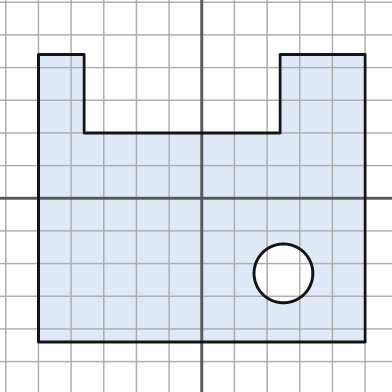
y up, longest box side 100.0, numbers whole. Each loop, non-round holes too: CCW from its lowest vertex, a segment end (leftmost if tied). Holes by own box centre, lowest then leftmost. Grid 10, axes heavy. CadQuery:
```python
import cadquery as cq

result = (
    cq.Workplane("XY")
    .moveTo(-50.0, -44.0)
    .lineTo(50.0, -44.0)
    .lineTo(50.0, 44.0)
    .lineTo(24.0, 44.0)
    .lineTo(24.0, 20.0)
    .lineTo(-36.0, 20.0)
    .lineTo(-36.0, 44.0)
    .lineTo(-50.0, 44.0)
    .close()
    .moveTo(25.0, -23.0)
    .circle(9.0)
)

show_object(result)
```